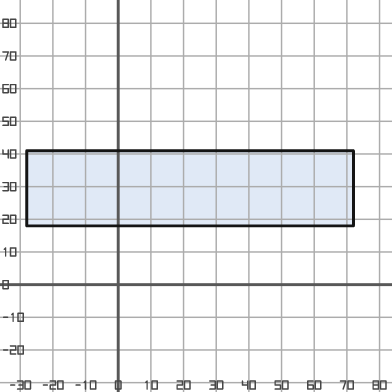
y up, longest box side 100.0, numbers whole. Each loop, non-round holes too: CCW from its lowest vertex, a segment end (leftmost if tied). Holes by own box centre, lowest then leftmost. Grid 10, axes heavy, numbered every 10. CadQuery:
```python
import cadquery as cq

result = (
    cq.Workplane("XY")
    .moveTo(-28.0, 18.0)
    .lineTo(72.0, 18.0)
    .lineTo(72.0, 41.0)
    .lineTo(-28.0, 41.0)
    .close()
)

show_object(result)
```